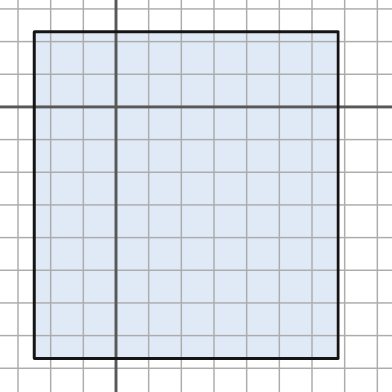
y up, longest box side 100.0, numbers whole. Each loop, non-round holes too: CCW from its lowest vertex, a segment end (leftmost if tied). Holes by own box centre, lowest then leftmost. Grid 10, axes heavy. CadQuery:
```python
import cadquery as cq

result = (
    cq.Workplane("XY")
    .moveTo(-25.0, -77.0)
    .lineTo(68.0, -77.0)
    .lineTo(68.0, 23.0)
    .lineTo(-25.0, 23.0)
    .close()
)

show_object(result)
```